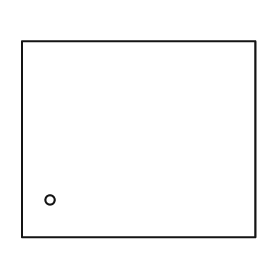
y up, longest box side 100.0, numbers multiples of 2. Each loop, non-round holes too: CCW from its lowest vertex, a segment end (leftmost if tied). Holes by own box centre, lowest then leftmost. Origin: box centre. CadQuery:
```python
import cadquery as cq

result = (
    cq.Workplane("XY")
    .moveTo(-50.0, -42.0)
    .lineTo(50.0, -42.0)
    .lineTo(50.0, 42.0)
    .lineTo(-50.0, 42.0)
    .close()
    .moveTo(-38.0, -26.0)
    .circle(2.0)
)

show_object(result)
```